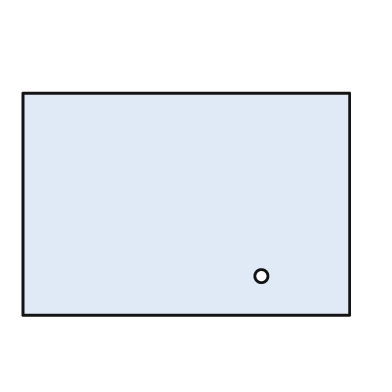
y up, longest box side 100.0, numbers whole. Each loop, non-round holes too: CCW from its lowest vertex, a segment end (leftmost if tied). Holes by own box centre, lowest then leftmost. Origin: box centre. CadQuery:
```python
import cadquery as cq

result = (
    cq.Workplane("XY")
    .moveTo(-50.0, -34.0)
    .lineTo(50.0, -34.0)
    .lineTo(50.0, 34.0)
    .lineTo(-50.0, 34.0)
    .close()
    .moveTo(23.0, -22.0)
    .circle(2.0)
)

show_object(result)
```